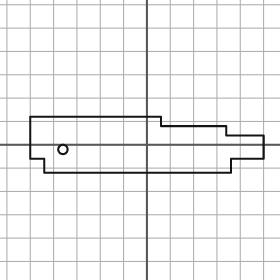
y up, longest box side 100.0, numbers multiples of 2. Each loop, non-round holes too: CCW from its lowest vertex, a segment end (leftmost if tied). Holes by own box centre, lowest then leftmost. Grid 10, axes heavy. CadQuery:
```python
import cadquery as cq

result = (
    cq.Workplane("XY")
    .moveTo(-44.0, -12.0)
    .lineTo(36.0, -12.0)
    .lineTo(36.0, -6.0)
    .lineTo(50.0, -6.0)
    .lineTo(50.0, 4.0)
    .lineTo(34.0, 4.0)
    .lineTo(34.0, 8.0)
    .lineTo(6.0, 8.0)
    .lineTo(6.0, 12.0)
    .lineTo(-50.0, 12.0)
    .lineTo(-50.0, -6.0)
    .lineTo(-44.0, -6.0)
    .close()
    .moveTo(-36.0, -2.0)
    .circle(2.0)
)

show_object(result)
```